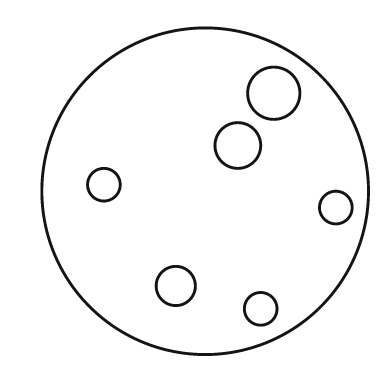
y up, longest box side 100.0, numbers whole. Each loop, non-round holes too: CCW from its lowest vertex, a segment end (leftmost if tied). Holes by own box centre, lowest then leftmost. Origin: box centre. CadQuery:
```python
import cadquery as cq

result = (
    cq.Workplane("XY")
    .moveTo(0.0, 0.0)
    .circle(50.0)
    .moveTo(17.0, -36.0)
    .circle(5.0)
    .moveTo(-9.0, -29.0)
    .circle(6.0)
    .moveTo(40.0, -5.0)
    .circle(5.0)
    .moveTo(-31.0, 2.0)
    .circle(5.0)
    .moveTo(10.0, 14.0)
    .circle(7.0)
    .moveTo(21.0, 30.0)
    .circle(8.0)
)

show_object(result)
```